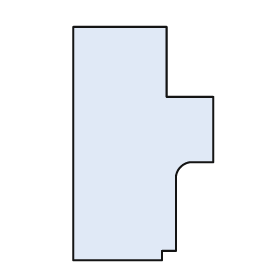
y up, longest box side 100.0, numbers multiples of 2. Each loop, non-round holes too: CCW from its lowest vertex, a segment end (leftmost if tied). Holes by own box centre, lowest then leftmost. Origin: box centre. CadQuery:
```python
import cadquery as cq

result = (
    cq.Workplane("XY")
    .moveTo(-30.0, -50.0)
    .lineTo(8.0, -50.0)
    .lineTo(8.0, -46.0)
    .lineTo(14.0, -46.0)
    .lineTo(14.0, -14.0)
    .threePointArc((16.0, -10.0), (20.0, -8.0))
    .lineTo(30.0, -8.0)
    .lineTo(30.0, 20.0)
    .lineTo(10.0, 20.0)
    .lineTo(10.0, 50.0)
    .lineTo(-30.0, 50.0)
    .close()
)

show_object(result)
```